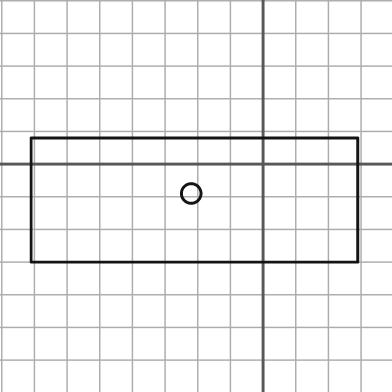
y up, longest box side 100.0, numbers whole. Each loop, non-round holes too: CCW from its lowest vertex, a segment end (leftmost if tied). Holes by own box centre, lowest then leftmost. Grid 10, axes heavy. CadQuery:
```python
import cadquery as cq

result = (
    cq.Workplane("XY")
    .moveTo(-71.0, -30.0)
    .lineTo(29.0, -30.0)
    .lineTo(29.0, 8.0)
    .lineTo(-71.0, 8.0)
    .close()
    .moveTo(-22.0, -9.0)
    .circle(3.0)
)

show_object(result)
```